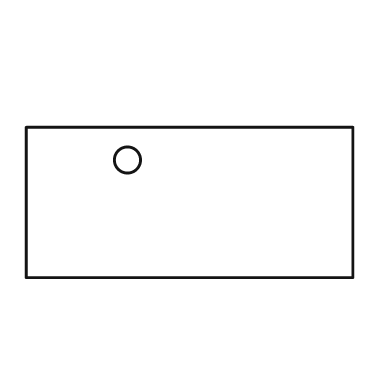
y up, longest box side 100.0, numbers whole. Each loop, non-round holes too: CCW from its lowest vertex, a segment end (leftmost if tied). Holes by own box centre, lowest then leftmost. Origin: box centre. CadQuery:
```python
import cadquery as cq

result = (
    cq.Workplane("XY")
    .moveTo(-50.0, -23.0)
    .lineTo(50.0, -23.0)
    .lineTo(50.0, 23.0)
    .lineTo(-50.0, 23.0)
    .close()
    .moveTo(-19.0, 13.0)
    .circle(4.0)
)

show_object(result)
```